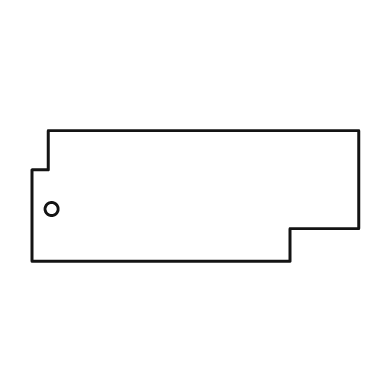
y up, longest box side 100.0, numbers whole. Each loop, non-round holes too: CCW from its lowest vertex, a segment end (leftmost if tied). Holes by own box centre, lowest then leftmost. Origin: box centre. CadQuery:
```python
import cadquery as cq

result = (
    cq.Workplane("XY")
    .moveTo(-50.0, -20.0)
    .lineTo(29.0, -20.0)
    .lineTo(29.0, -10.0)
    .lineTo(50.0, -10.0)
    .lineTo(50.0, 20.0)
    .lineTo(-45.0, 20.0)
    .lineTo(-45.0, 8.0)
    .lineTo(-50.0, 8.0)
    .close()
    .moveTo(-44.0, -4.0)
    .circle(2.0)
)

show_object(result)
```